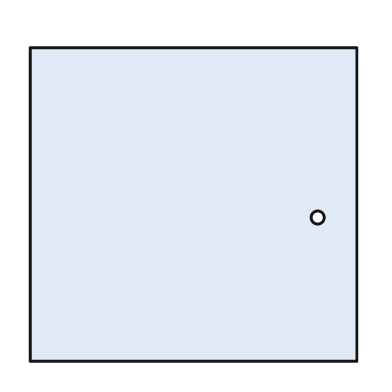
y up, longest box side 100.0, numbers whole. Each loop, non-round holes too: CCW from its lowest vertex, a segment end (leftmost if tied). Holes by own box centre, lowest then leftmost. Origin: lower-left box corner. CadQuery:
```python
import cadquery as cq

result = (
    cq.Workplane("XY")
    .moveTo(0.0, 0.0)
    .lineTo(100.0, 0.0)
    .lineTo(100.0, 96.0)
    .lineTo(0.0, 96.0)
    .close()
    .moveTo(88.0, 44.0)
    .circle(2.0)
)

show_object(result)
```